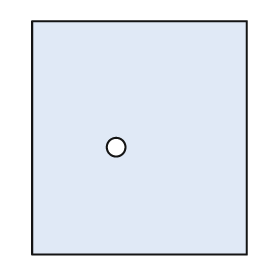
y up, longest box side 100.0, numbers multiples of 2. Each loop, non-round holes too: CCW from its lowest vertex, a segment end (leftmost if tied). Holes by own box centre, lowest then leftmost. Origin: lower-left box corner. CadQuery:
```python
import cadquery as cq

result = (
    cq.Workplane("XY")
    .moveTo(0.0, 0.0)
    .lineTo(92.0, 0.0)
    .lineTo(92.0, 100.0)
    .lineTo(0.0, 100.0)
    .close()
    .moveTo(36.0, 46.0)
    .circle(4.0)
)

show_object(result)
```